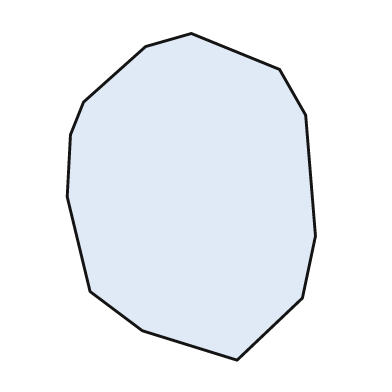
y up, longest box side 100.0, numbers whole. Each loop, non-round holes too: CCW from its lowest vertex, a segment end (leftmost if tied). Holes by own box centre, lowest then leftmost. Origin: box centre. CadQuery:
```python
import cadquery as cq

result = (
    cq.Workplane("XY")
    .moveTo(14.0, -50.0)
    .lineTo(34.0, -31.0)
    .lineTo(38.0, -12.0)
    .lineTo(35.0, 25.0)
    .lineTo(27.0, 39.0)
    .lineTo(0.0, 50.0)
    .lineTo(-14.0, 46.0)
    .lineTo(-33.0, 29.0)
    .lineTo(-37.0, 19.0)
    .lineTo(-38.0, 0.0)
    .lineTo(-31.0, -29.0)
    .lineTo(-15.0, -41.0)
    .close()
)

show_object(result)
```